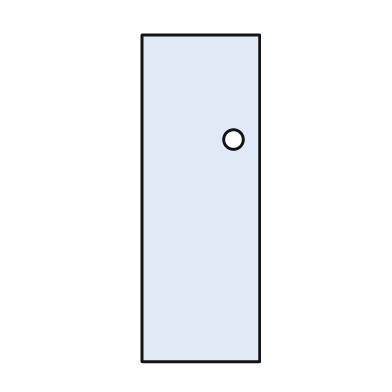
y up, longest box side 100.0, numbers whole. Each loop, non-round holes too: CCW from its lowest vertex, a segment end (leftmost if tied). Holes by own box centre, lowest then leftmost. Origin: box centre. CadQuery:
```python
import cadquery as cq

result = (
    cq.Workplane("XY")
    .moveTo(-18.0, -50.0)
    .lineTo(18.0, -50.0)
    .lineTo(18.0, 50.0)
    .lineTo(-18.0, 50.0)
    .close()
    .moveTo(10.0, 18.0)
    .circle(3.0)
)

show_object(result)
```